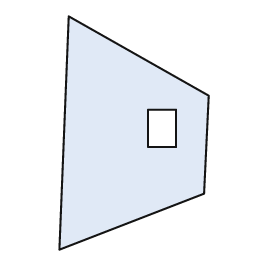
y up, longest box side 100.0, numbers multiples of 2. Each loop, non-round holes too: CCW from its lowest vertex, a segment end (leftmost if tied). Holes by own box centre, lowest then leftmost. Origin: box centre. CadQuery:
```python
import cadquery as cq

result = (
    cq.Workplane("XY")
    .moveTo(-32.0, -50.0)
    .lineTo(30.0, -26.0)
    .lineTo(32.0, 16.0)
    .lineTo(-28.0, 50.0)
    .close()
    .moveTo(6.0, -6.0)
    .lineTo(18.0, -6.0)
    .lineTo(18.0, 10.0)
    .lineTo(6.0, 10.0)
    .close()
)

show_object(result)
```